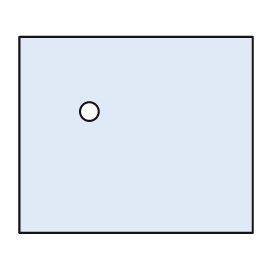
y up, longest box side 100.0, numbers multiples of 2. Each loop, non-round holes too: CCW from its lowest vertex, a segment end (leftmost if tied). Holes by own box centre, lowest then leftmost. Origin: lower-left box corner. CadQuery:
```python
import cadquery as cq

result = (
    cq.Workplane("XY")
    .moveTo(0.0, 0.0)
    .lineTo(100.0, 0.0)
    .lineTo(100.0, 84.0)
    .lineTo(0.0, 84.0)
    .close()
    .moveTo(30.0, 52.0)
    .circle(4.0)
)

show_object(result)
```